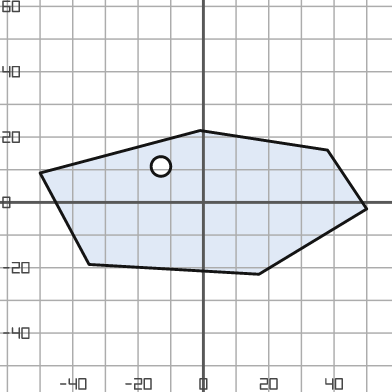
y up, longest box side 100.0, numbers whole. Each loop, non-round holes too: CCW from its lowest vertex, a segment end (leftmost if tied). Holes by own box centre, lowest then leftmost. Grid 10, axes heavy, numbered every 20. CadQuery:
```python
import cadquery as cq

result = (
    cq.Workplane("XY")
    .moveTo(17.0, -22.0)
    .lineTo(50.0, -2.0)
    .lineTo(38.0, 16.0)
    .lineTo(-1.0, 22.0)
    .lineTo(-50.0, 9.0)
    .lineTo(-35.0, -19.0)
    .close()
    .moveTo(-13.0, 11.0)
    .circle(3.0)
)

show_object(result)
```